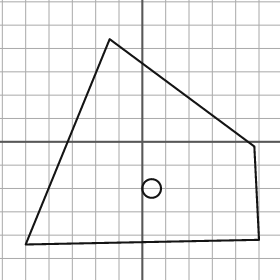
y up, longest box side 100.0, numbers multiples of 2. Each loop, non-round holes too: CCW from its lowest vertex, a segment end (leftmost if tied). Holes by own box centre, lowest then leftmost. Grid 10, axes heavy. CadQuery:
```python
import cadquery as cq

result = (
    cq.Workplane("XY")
    .moveTo(-50.0, -44.0)
    .lineTo(50.0, -42.0)
    .lineTo(48.0, -2.0)
    .lineTo(-14.0, 44.0)
    .close()
    .moveTo(4.0, -20.0)
    .circle(4.0)
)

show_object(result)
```